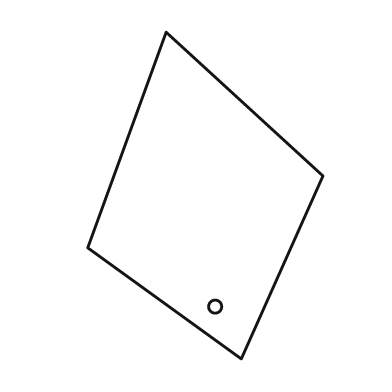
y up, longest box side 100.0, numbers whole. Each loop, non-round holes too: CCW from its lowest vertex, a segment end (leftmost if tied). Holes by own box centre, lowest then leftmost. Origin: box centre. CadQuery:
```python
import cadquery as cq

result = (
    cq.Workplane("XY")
    .moveTo(11.0, -50.0)
    .lineTo(36.0, 6.0)
    .lineTo(-12.0, 50.0)
    .lineTo(-36.0, -16.0)
    .close()
    .moveTo(3.0, -34.0)
    .circle(2.0)
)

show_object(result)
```